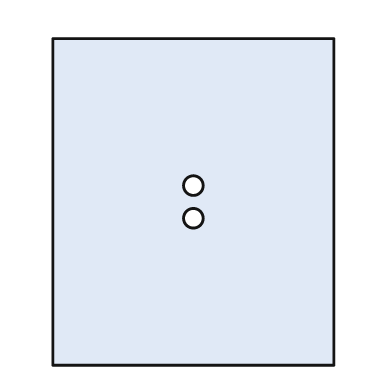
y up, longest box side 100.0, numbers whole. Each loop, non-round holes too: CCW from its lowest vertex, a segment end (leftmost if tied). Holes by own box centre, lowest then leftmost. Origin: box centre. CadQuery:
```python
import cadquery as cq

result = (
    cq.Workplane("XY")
    .moveTo(-43.0, -50.0)
    .lineTo(43.0, -50.0)
    .lineTo(43.0, 50.0)
    .lineTo(-43.0, 50.0)
    .close()
    .moveTo(0.0, -5.0)
    .circle(3.0)
    .moveTo(0.0, 5.0)
    .circle(3.0)
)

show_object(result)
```